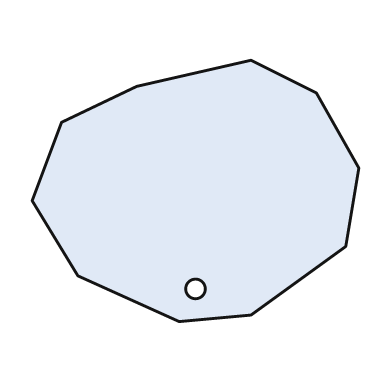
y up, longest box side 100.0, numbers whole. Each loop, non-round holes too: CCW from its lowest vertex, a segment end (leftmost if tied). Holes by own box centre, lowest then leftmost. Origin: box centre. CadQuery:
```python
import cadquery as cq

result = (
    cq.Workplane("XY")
    .moveTo(-5.0, -40.0)
    .lineTo(17.0, -38.0)
    .lineTo(46.0, -17.0)
    .lineTo(50.0, 7.0)
    .lineTo(37.0, 30.0)
    .lineTo(17.0, 40.0)
    .lineTo(-18.0, 32.0)
    .lineTo(-41.0, 21.0)
    .lineTo(-50.0, -3.0)
    .lineTo(-36.0, -26.0)
    .close()
    .moveTo(0.0, -30.0)
    .circle(3.0)
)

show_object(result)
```